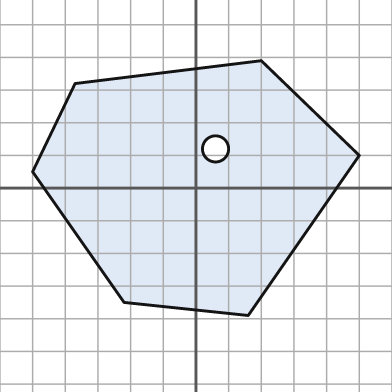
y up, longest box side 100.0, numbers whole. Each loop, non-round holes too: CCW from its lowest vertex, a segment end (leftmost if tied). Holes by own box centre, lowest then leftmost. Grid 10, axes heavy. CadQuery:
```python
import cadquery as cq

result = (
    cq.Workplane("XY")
    .moveTo(16.0, -39.0)
    .lineTo(50.0, 10.0)
    .lineTo(20.0, 39.0)
    .lineTo(-37.0, 32.0)
    .lineTo(-50.0, 5.0)
    .lineTo(-22.0, -35.0)
    .close()
    .moveTo(6.0, 12.0)
    .circle(4.0)
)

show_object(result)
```